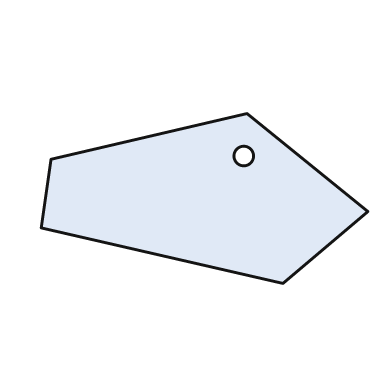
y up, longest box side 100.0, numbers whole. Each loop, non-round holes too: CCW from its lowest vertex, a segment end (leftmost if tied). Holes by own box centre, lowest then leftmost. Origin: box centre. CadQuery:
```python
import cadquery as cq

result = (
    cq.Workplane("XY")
    .moveTo(24.0, -26.0)
    .lineTo(50.0, -4.0)
    .lineTo(13.0, 26.0)
    .lineTo(-47.0, 12.0)
    .lineTo(-50.0, -9.0)
    .close()
    .moveTo(12.0, 13.0)
    .circle(3.0)
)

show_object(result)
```